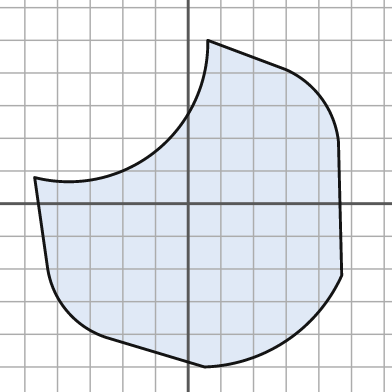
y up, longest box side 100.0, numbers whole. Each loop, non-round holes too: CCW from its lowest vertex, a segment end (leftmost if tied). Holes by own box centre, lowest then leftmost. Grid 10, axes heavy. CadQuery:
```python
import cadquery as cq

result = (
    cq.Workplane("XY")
    .moveTo(5.0, -50.0)
    .threePointArc((30.0, -42.0), (47.0, -22.0))
    .lineTo(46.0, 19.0)
    .threePointArc((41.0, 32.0), (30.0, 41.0))
    .lineTo(6.0, 50.0)
    .threePointArc((-10.0, 16.0), (-47.0, 8.0))
    .lineTo(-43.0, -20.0)
    .threePointArc((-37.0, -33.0), (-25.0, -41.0))
    .close()
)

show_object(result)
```